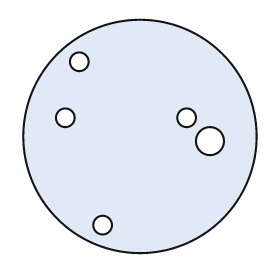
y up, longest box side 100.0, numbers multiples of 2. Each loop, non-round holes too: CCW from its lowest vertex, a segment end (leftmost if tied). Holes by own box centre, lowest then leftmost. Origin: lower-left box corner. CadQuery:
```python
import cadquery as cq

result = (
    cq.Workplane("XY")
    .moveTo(50.0, 50.0)
    .circle(50.0)
    .moveTo(34.0, 12.0)
    .circle(4.0)
    .moveTo(80.0, 48.0)
    .circle(6.0)
    .moveTo(18.0, 58.0)
    .circle(4.0)
    .moveTo(70.0, 58.0)
    .circle(4.0)
    .moveTo(24.0, 82.0)
    .circle(4.0)
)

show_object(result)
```